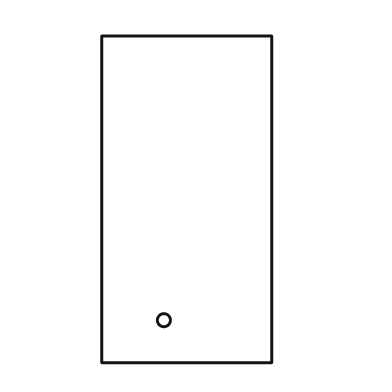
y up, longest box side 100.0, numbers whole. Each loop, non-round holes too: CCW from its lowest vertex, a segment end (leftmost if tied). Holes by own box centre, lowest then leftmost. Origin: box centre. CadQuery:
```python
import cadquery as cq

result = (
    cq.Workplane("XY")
    .moveTo(-26.0, -50.0)
    .lineTo(26.0, -50.0)
    .lineTo(26.0, 50.0)
    .lineTo(-26.0, 50.0)
    .close()
    .moveTo(-7.0, -37.0)
    .circle(2.0)
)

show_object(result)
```